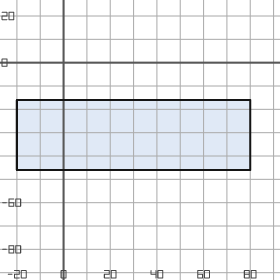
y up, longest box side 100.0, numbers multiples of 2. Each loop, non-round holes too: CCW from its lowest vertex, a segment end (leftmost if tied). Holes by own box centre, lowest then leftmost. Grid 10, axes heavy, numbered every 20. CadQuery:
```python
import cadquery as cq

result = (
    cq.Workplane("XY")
    .moveTo(-20.0, -46.0)
    .lineTo(80.0, -46.0)
    .lineTo(80.0, -16.0)
    .lineTo(-20.0, -16.0)
    .close()
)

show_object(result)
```